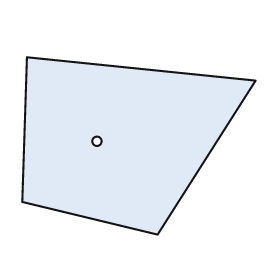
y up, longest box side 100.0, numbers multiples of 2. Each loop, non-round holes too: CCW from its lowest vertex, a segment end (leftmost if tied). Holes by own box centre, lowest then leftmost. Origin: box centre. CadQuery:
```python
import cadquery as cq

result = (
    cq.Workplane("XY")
    .moveTo(8.0, -38.0)
    .lineTo(50.0, 28.0)
    .lineTo(-48.0, 38.0)
    .lineTo(-50.0, -24.0)
    .close()
    .moveTo(-18.0, 2.0)
    .circle(2.0)
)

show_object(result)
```